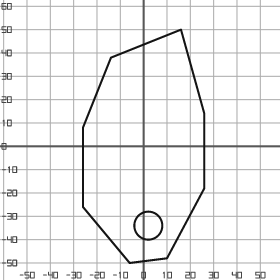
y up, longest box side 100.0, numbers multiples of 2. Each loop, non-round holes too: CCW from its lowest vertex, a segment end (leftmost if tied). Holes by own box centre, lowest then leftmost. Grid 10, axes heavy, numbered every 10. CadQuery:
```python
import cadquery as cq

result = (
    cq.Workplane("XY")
    .moveTo(-6.0, -50.0)
    .lineTo(10.0, -48.0)
    .lineTo(26.0, -18.0)
    .lineTo(26.0, 14.0)
    .lineTo(16.0, 50.0)
    .lineTo(-14.0, 38.0)
    .lineTo(-26.0, 8.0)
    .lineTo(-26.0, -26.0)
    .close()
    .moveTo(2.0, -34.0)
    .circle(6.0)
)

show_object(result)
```